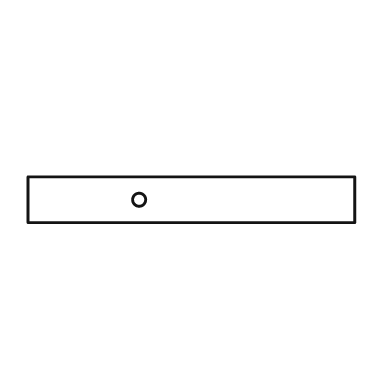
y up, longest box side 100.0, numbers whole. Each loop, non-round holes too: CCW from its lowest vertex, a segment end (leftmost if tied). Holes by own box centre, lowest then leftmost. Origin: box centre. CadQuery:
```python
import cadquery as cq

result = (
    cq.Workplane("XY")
    .moveTo(-50.0, -7.0)
    .lineTo(50.0, -7.0)
    .lineTo(50.0, 7.0)
    .lineTo(-50.0, 7.0)
    .close()
    .moveTo(-16.0, 0.0)
    .circle(2.0)
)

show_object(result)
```